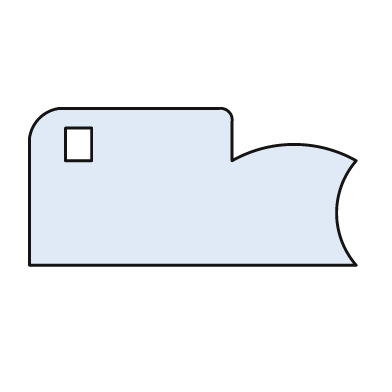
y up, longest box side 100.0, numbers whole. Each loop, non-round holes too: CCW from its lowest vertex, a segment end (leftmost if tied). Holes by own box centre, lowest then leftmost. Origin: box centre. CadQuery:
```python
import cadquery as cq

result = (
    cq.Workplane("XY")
    .moveTo(-50.0, -24.0)
    .lineTo(50.0, -24.0)
    .threePointArc((44.0, -8.0), (50.0, 8.0))
    .threePointArc((31.0, 13.0), (12.0, 8.0))
    .lineTo(12.0, 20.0)
    .threePointArc((11.0, 23.0), (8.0, 24.0))
    .lineTo(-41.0, 24.0)
    .threePointArc((-47.0, 21.0), (-50.0, 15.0))
    .close()
    .moveTo(-39.0, 8.0)
    .lineTo(-31.0, 8.0)
    .lineTo(-31.0, 18.0)
    .lineTo(-39.0, 18.0)
    .close()
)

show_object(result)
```